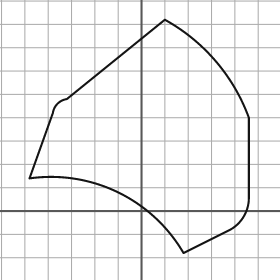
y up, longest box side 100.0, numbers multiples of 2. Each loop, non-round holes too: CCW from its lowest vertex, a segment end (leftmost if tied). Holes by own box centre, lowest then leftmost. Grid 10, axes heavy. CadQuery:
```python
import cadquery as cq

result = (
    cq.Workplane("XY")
    .moveTo(18.0, -18.0)
    .lineTo(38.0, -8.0)
    .threePointArc((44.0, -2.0), (46.0, 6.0))
    .lineTo(46.0, 40.0)
    .threePointArc((32.0, 64.0), (10.0, 82.0))
    .lineTo(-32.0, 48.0)
    .threePointArc((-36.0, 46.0), (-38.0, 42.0))
    .lineTo(-48.0, 14.0)
    .threePointArc((-10.0, 8.0), (18.0, -18.0))
    .close()
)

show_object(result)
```